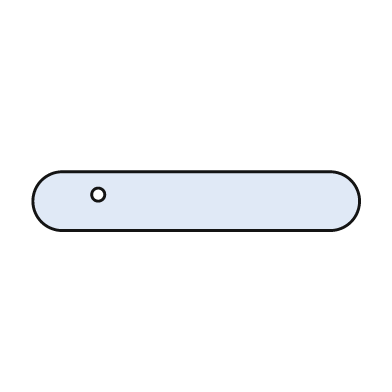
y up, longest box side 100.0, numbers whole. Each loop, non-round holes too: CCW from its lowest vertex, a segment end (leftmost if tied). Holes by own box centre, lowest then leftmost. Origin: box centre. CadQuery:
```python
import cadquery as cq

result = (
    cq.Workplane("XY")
    .moveTo(-41.0, -9.0)
    .lineTo(41.0, -9.0)
    .threePointArc((50.0, 0.0), (41.0, 9.0))
    .lineTo(-41.0, 9.0)
    .threePointArc((-50.0, 0.0), (-41.0, -9.0))
    .close()
    .moveTo(-30.0, 2.0)
    .circle(2.0)
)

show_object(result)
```